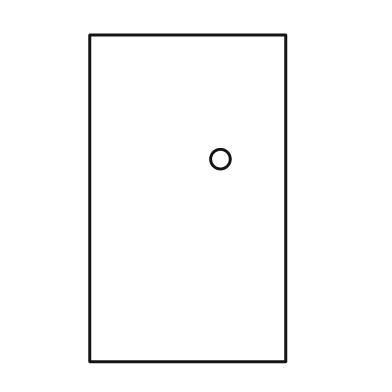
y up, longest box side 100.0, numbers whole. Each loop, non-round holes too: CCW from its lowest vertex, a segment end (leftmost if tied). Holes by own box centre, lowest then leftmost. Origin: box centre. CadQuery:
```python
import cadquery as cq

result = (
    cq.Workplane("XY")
    .moveTo(-30.0, -50.0)
    .lineTo(30.0, -50.0)
    .lineTo(30.0, 50.0)
    .lineTo(-30.0, 50.0)
    .close()
    .moveTo(10.0, 12.0)
    .circle(3.0)
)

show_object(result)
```